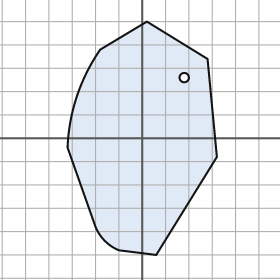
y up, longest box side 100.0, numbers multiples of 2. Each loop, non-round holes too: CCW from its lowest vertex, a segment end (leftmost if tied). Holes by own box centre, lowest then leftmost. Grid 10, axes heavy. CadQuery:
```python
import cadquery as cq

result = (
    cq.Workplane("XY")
    .moveTo(6.0, -50.0)
    .lineTo(32.0, -8.0)
    .lineTo(28.0, 34.0)
    .lineTo(2.0, 50.0)
    .lineTo(-18.0, 38.0)
    .threePointArc((-28.0, 18.0), (-32.0, -4.0))
    .lineTo(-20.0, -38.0)
    .threePointArc((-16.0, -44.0), (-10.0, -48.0))
    .close()
    .moveTo(18.0, 26.0)
    .circle(2.0)
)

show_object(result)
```